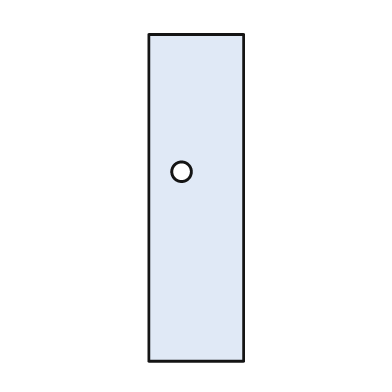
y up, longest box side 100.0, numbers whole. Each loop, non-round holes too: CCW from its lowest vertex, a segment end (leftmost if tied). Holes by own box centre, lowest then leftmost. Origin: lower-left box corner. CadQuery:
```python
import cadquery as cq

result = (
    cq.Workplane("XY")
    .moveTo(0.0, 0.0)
    .lineTo(29.0, 0.0)
    .lineTo(29.0, 100.0)
    .lineTo(0.0, 100.0)
    .close()
    .moveTo(10.0, 58.0)
    .circle(3.0)
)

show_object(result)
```